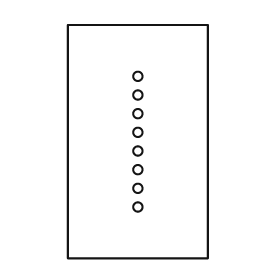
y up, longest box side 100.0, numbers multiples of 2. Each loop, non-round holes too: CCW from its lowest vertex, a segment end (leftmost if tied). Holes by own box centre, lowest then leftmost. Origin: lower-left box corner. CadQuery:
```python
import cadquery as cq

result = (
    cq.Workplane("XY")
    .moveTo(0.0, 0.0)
    .lineTo(60.0, 0.0)
    .lineTo(60.0, 100.0)
    .lineTo(0.0, 100.0)
    .close()
    .moveTo(30.0, 22.0)
    .circle(2.0)
    .moveTo(30.0, 30.0)
    .circle(2.0)
    .moveTo(30.0, 38.0)
    .circle(2.0)
    .moveTo(30.0, 46.0)
    .circle(2.0)
    .moveTo(30.0, 54.0)
    .circle(2.0)
    .moveTo(30.0, 62.0)
    .circle(2.0)
    .moveTo(30.0, 70.0)
    .circle(2.0)
    .moveTo(30.0, 78.0)
    .circle(2.0)
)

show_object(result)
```